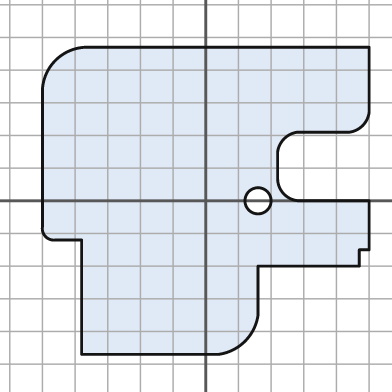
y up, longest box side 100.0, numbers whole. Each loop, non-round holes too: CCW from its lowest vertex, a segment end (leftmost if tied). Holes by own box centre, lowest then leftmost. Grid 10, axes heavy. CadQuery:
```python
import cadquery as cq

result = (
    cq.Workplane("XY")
    .moveTo(-38.0, -47.0)
    .lineTo(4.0, -47.0)
    .threePointArc((12.0, -43.0), (16.0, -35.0))
    .lineTo(16.0, -20.0)
    .lineTo(47.0, -20.0)
    .lineTo(47.0, -15.0)
    .lineTo(50.0, -15.0)
    .lineTo(50.0, 0.0)
    .lineTo(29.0, 0.0)
    .threePointArc((24.0, 2.0), (22.0, 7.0))
    .lineTo(22.0, 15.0)
    .threePointArc((24.0, 19.0), (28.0, 21.0))
    .lineTo(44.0, 21.0)
    .threePointArc((48.0, 23.0), (50.0, 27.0))
    .lineTo(50.0, 47.0)
    .lineTo(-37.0, 47.0)
    .threePointArc((-46.0, 43.0), (-50.0, 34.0))
    .lineTo(-50.0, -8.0)
    .threePointArc((-49.0, -11.0), (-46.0, -12.0))
    .lineTo(-38.0, -12.0)
    .close()
    .moveTo(16.0, 0.0)
    .circle(4.0)
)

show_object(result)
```